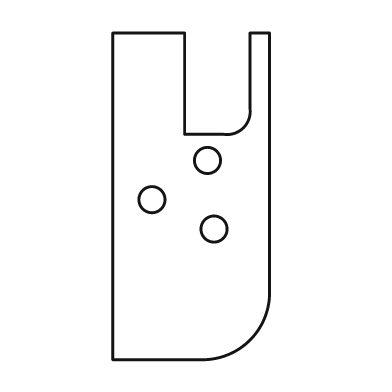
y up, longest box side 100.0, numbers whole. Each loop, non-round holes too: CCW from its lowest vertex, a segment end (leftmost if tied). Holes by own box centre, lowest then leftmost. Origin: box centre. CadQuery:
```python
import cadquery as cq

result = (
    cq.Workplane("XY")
    .moveTo(-24.0, -50.0)
    .lineTo(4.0, -50.0)
    .threePointArc((18.0, -44.0), (24.0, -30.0))
    .lineTo(24.0, 50.0)
    .lineTo(18.0, 50.0)
    .lineTo(18.0, 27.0)
    .threePointArc((16.0, 21.0), (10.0, 19.0))
    .lineTo(-2.0, 19.0)
    .lineTo(-2.0, 50.0)
    .lineTo(-24.0, 50.0)
    .close()
    .moveTo(7.0, -10.0)
    .circle(4.0)
    .moveTo(-12.0, -1.0)
    .circle(4.0)
    .moveTo(5.0, 11.0)
    .circle(4.0)
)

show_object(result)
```